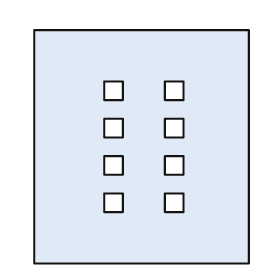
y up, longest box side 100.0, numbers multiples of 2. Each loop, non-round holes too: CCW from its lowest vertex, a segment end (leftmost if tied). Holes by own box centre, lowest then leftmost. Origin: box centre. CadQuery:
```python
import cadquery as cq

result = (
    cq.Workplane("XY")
    .moveTo(-46.0, -50.0)
    .lineTo(46.0, -50.0)
    .lineTo(46.0, 50.0)
    .lineTo(-46.0, 50.0)
    .close()
    .moveTo(-16.0, -28.0)
    .lineTo(-8.0, -28.0)
    .lineTo(-8.0, -20.0)
    .lineTo(-16.0, -20.0)
    .close()
    .moveTo(10.0, -28.0)
    .lineTo(18.0, -28.0)
    .lineTo(18.0, -20.0)
    .lineTo(10.0, -20.0)
    .close()
    .moveTo(-16.0, -12.0)
    .lineTo(-8.0, -12.0)
    .lineTo(-8.0, -4.0)
    .lineTo(-16.0, -4.0)
    .close()
    .moveTo(10.0, -12.0)
    .lineTo(18.0, -12.0)
    .lineTo(18.0, -4.0)
    .lineTo(10.0, -4.0)
    .close()
    .moveTo(-16.0, 4.0)
    .lineTo(-8.0, 4.0)
    .lineTo(-8.0, 12.0)
    .lineTo(-16.0, 12.0)
    .close()
    .moveTo(10.0, 4.0)
    .lineTo(18.0, 4.0)
    .lineTo(18.0, 12.0)
    .lineTo(10.0, 12.0)
    .close()
    .moveTo(-16.0, 20.0)
    .lineTo(-8.0, 20.0)
    .lineTo(-8.0, 28.0)
    .lineTo(-16.0, 28.0)
    .close()
    .moveTo(10.0, 20.0)
    .lineTo(18.0, 20.0)
    .lineTo(18.0, 28.0)
    .lineTo(10.0, 28.0)
    .close()
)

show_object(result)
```